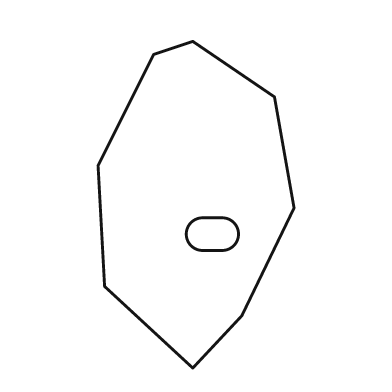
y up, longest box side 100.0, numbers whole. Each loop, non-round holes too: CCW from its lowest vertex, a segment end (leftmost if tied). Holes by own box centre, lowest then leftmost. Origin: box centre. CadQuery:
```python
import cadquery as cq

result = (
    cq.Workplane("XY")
    .moveTo(-1.0, -50.0)
    .lineTo(14.0, -34.0)
    .lineTo(30.0, -1.0)
    .lineTo(24.0, 33.0)
    .lineTo(-1.0, 50.0)
    .lineTo(-13.0, 46.0)
    .lineTo(-30.0, 12.0)
    .lineTo(-28.0, -25.0)
    .close()
    .moveTo(2.0, -14.0)
    .lineTo(8.0, -14.0)
    .threePointArc((13.0, -9.0), (8.0, -4.0))
    .lineTo(2.0, -4.0)
    .threePointArc((-3.0, -9.0), (2.0, -14.0))
    .close()
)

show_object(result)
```